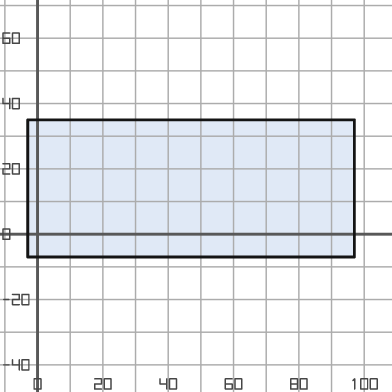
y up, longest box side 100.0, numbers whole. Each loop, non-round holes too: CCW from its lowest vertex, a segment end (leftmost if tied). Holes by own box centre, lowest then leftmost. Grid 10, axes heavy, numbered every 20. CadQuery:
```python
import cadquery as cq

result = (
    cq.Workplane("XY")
    .moveTo(-3.0, -7.0)
    .lineTo(97.0, -7.0)
    .lineTo(97.0, 35.0)
    .lineTo(-3.0, 35.0)
    .close()
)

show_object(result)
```